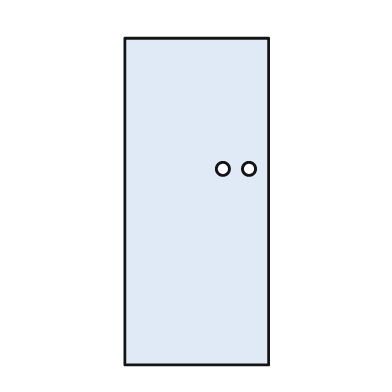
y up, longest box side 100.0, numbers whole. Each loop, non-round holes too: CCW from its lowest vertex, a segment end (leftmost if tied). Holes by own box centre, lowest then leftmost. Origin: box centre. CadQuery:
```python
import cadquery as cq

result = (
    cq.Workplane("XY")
    .moveTo(-22.0, -50.0)
    .lineTo(22.0, -50.0)
    .lineTo(22.0, 50.0)
    .lineTo(-22.0, 50.0)
    .close()
    .moveTo(8.0, 10.0)
    .circle(2.0)
    .moveTo(16.0, 10.0)
    .circle(2.0)
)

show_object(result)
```